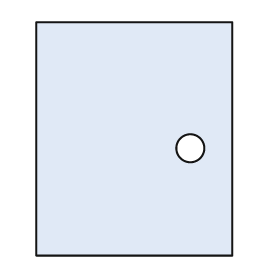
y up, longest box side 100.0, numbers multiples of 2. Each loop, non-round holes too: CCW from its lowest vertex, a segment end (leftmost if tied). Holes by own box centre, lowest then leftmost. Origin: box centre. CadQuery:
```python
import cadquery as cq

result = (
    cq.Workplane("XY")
    .moveTo(-42.0, -50.0)
    .lineTo(42.0, -50.0)
    .lineTo(42.0, 50.0)
    .lineTo(-42.0, 50.0)
    .close()
    .moveTo(24.0, -4.0)
    .circle(6.0)
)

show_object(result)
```